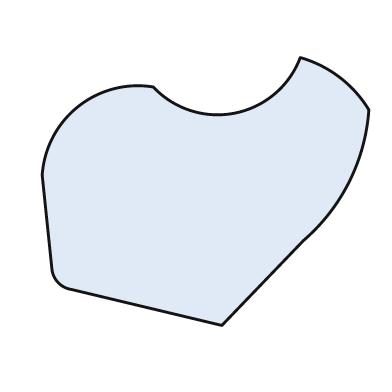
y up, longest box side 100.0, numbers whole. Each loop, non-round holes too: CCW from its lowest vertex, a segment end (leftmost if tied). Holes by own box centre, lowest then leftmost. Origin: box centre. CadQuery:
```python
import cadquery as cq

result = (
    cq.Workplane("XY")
    .moveTo(5.0, -41.0)
    .lineTo(30.0, -15.0)
    .threePointArc((44.0, 3.0), (50.0, 25.0))
    .threePointArc((41.0, 35.0), (29.0, 41.0))
    .threePointArc((9.0, 24.0), (-16.0, 32.0))
    .threePointArc((-39.0, 26.0), (-50.0, 5.0))
    .lineTo(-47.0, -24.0)
    .threePointArc((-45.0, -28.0), (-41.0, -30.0))
    .close()
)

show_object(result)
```